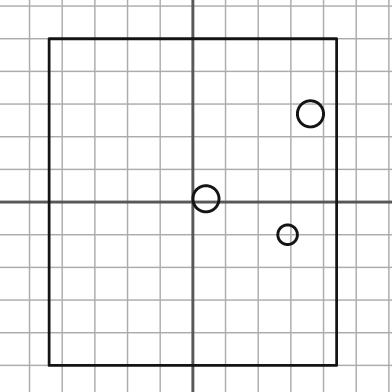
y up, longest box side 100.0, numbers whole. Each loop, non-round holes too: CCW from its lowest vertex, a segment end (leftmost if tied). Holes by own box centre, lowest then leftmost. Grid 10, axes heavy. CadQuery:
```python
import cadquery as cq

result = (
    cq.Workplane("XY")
    .moveTo(-44.0, -50.0)
    .lineTo(44.0, -50.0)
    .lineTo(44.0, 50.0)
    .lineTo(-44.0, 50.0)
    .close()
    .moveTo(29.0, -10.0)
    .circle(3.0)
    .moveTo(4.0, 1.0)
    .circle(4.0)
    .moveTo(36.0, 27.0)
    .circle(4.0)
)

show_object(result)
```